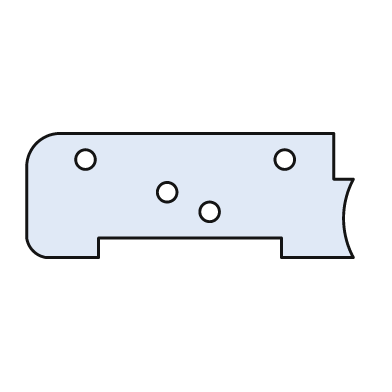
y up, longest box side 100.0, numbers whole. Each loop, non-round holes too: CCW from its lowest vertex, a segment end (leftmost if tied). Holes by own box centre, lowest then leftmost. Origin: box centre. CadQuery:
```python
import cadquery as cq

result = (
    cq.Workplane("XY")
    .moveTo(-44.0, -19.0)
    .lineTo(-28.0, -19.0)
    .lineTo(-28.0, -13.0)
    .lineTo(28.0, -13.0)
    .lineTo(28.0, -19.0)
    .lineTo(50.0, -19.0)
    .threePointArc((47.0, -7.0), (50.0, 5.0))
    .lineTo(44.0, 5.0)
    .lineTo(44.0, 19.0)
    .lineTo(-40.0, 19.0)
    .threePointArc((-47.0, 16.0), (-50.0, 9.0))
    .lineTo(-50.0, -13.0)
    .threePointArc((-48.0, -17.0), (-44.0, -19.0))
    .close()
    .moveTo(6.0, -5.0)
    .circle(3.0)
    .moveTo(-7.0, 1.0)
    .circle(3.0)
    .moveTo(-32.0, 11.0)
    .circle(3.0)
    .moveTo(29.0, 11.0)
    .circle(3.0)
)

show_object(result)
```